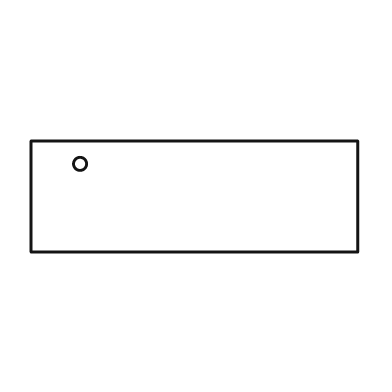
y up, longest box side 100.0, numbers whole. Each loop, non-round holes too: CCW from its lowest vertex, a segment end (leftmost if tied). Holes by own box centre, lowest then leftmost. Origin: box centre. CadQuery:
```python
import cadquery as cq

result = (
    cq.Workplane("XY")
    .moveTo(-50.0, -17.0)
    .lineTo(50.0, -17.0)
    .lineTo(50.0, 17.0)
    .lineTo(-50.0, 17.0)
    .close()
    .moveTo(-35.0, 10.0)
    .circle(2.0)
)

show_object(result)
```